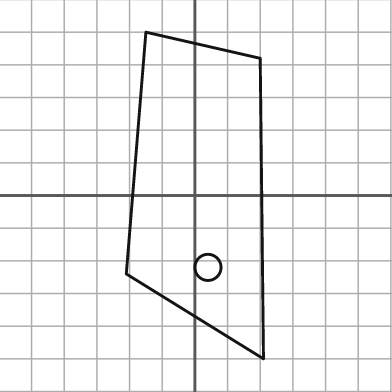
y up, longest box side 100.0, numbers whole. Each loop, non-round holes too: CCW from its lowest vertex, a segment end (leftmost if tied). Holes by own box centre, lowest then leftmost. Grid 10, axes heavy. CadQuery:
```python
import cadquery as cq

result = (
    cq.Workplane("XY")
    .moveTo(21.0, -50.0)
    .lineTo(20.0, 42.0)
    .lineTo(-15.0, 50.0)
    .lineTo(-21.0, -24.0)
    .close()
    .moveTo(4.0, -22.0)
    .circle(4.0)
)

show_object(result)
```